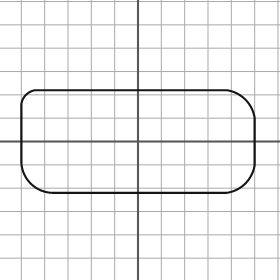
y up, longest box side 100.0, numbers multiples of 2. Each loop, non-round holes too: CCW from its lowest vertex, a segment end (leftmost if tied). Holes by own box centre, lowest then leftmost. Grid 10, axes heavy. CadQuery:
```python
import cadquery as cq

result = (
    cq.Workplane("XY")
    .moveTo(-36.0, -22.0)
    .lineTo(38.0, -22.0)
    .threePointArc((46.0, -18.0), (50.0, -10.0))
    .lineTo(50.0, 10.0)
    .threePointArc((46.0, 18.0), (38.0, 22.0))
    .lineTo(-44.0, 22.0)
    .threePointArc((-48.0, 20.0), (-50.0, 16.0))
    .lineTo(-50.0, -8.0)
    .threePointArc((-46.0, -18.0), (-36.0, -22.0))
    .close()
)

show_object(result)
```